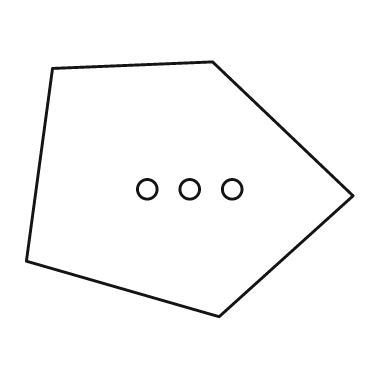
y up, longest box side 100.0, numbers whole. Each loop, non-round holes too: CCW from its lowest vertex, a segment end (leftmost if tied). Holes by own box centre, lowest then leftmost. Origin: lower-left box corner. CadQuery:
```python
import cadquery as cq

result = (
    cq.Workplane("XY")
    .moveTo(59.0, 0.0)
    .lineTo(100.0, 37.0)
    .lineTo(57.0, 78.0)
    .lineTo(8.0, 76.0)
    .lineTo(0.0, 17.0)
    .close()
    .moveTo(37.0, 39.0)
    .circle(3.0)
    .moveTo(50.0, 39.0)
    .circle(3.0)
    .moveTo(63.0, 39.0)
    .circle(3.0)
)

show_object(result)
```